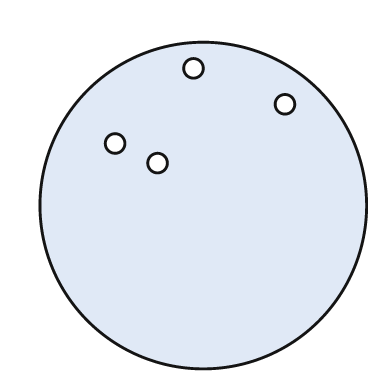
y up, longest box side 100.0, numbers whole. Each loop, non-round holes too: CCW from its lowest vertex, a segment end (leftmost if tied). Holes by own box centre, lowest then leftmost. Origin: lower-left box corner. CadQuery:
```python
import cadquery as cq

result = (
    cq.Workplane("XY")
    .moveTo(50.0, 50.0)
    .circle(50.0)
    .moveTo(36.0, 63.0)
    .circle(3.0)
    .moveTo(23.0, 69.0)
    .circle(3.0)
    .moveTo(75.0, 81.0)
    .circle(3.0)
    .moveTo(47.0, 92.0)
    .circle(3.0)
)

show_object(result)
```